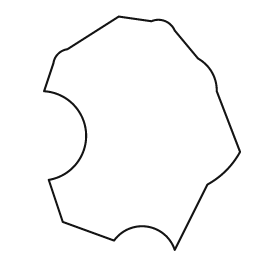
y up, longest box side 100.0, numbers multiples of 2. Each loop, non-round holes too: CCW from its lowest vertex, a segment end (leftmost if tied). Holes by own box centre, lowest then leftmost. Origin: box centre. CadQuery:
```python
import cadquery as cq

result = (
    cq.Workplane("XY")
    .moveTo(14.0, -50.0)
    .lineTo(28.0, -22.0)
    .threePointArc((36.0, -16.0), (42.0, -8.0))
    .lineTo(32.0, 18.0)
    .threePointArc((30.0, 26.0), (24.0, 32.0))
    .lineTo(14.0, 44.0)
    .threePointArc((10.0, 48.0), (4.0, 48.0))
    .lineTo(-10.0, 50.0)
    .lineTo(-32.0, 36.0)
    .threePointArc((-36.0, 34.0), (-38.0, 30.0))
    .lineTo(-42.0, 18.0)
    .threePointArc((-24.0, 0.0), (-40.0, -20.0))
    .lineTo(-34.0, -38.0)
    .lineTo(-12.0, -46.0)
    .threePointArc((2.0, -40.0), (14.0, -50.0))
    .close()
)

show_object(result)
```